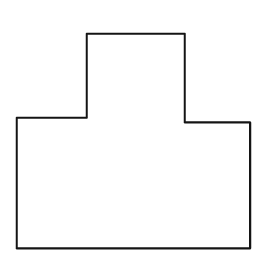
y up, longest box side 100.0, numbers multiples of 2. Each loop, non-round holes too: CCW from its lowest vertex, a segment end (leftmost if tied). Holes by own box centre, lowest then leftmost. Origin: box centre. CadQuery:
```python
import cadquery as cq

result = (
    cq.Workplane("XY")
    .moveTo(-50.0, -46.0)
    .lineTo(50.0, -46.0)
    .lineTo(50.0, 8.0)
    .lineTo(22.0, 8.0)
    .lineTo(22.0, 46.0)
    .lineTo(-20.0, 46.0)
    .lineTo(-20.0, 10.0)
    .lineTo(-50.0, 10.0)
    .close()
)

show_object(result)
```